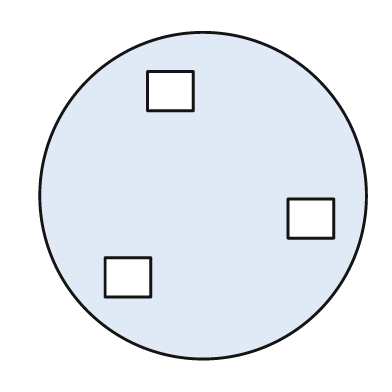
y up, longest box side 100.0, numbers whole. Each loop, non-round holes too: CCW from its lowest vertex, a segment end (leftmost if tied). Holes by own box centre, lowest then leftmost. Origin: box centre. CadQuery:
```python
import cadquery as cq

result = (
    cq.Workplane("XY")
    .moveTo(0.0, 0.0)
    .circle(50.0)
    .moveTo(-30.0, -31.0)
    .lineTo(-16.0, -31.0)
    .lineTo(-16.0, -19.0)
    .lineTo(-30.0, -19.0)
    .close()
    .moveTo(26.0, -13.0)
    .lineTo(40.0, -13.0)
    .lineTo(40.0, -1.0)
    .lineTo(26.0, -1.0)
    .close()
    .moveTo(-17.0, 26.0)
    .lineTo(-3.0, 26.0)
    .lineTo(-3.0, 38.0)
    .lineTo(-17.0, 38.0)
    .close()
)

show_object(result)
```